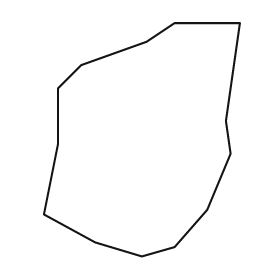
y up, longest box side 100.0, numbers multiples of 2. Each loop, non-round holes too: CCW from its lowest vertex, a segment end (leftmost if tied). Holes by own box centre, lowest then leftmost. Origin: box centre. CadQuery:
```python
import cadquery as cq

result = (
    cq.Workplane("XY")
    .moveTo(0.0, -50.0)
    .lineTo(14.0, -46.0)
    .lineTo(28.0, -30.0)
    .lineTo(38.0, -6.0)
    .lineTo(36.0, 8.0)
    .lineTo(42.0, 50.0)
    .lineTo(14.0, 50.0)
    .lineTo(2.0, 42.0)
    .lineTo(-26.0, 32.0)
    .lineTo(-36.0, 22.0)
    .lineTo(-36.0, -2.0)
    .lineTo(-42.0, -32.0)
    .lineTo(-20.0, -44.0)
    .close()
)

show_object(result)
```